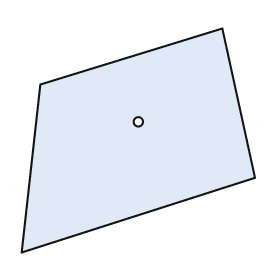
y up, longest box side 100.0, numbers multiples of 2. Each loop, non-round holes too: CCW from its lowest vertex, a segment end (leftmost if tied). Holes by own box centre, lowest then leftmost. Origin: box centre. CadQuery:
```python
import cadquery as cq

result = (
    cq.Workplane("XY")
    .moveTo(-50.0, -48.0)
    .lineTo(50.0, -16.0)
    .lineTo(36.0, 48.0)
    .lineTo(-42.0, 24.0)
    .close()
    .moveTo(0.0, 8.0)
    .circle(2.0)
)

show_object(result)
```